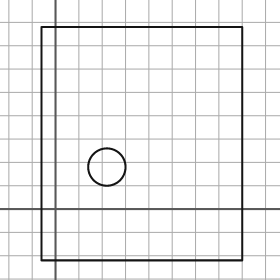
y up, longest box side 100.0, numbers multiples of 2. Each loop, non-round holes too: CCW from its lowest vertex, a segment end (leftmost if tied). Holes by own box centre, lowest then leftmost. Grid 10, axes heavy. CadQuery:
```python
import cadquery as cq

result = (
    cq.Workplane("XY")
    .moveTo(-6.0, -22.0)
    .lineTo(80.0, -22.0)
    .lineTo(80.0, 78.0)
    .lineTo(-6.0, 78.0)
    .close()
    .moveTo(22.0, 18.0)
    .circle(8.0)
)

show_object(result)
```